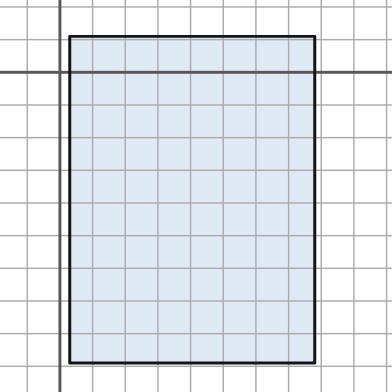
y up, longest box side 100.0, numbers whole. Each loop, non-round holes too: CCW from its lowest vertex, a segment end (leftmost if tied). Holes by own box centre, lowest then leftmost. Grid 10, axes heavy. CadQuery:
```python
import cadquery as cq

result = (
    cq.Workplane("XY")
    .moveTo(3.0, -89.0)
    .lineTo(78.0, -89.0)
    .lineTo(78.0, 11.0)
    .lineTo(3.0, 11.0)
    .close()
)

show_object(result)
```